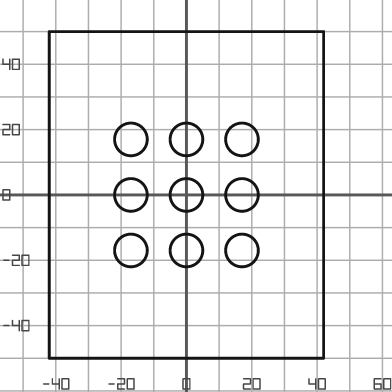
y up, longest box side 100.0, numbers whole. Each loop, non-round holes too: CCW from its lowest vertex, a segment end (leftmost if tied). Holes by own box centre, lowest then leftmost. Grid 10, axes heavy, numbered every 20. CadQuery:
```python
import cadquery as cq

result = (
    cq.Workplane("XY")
    .moveTo(-42.0, -50.0)
    .lineTo(42.0, -50.0)
    .lineTo(42.0, 50.0)
    .lineTo(-42.0, 50.0)
    .close()
    .moveTo(-17.0, -17.0)
    .circle(5.0)
    .moveTo(0.0, -17.0)
    .circle(5.0)
    .moveTo(17.0, -17.0)
    .circle(5.0)
    .moveTo(-17.0, 0.0)
    .circle(5.0)
    .moveTo(0.0, 0.0)
    .circle(5.0)
    .moveTo(17.0, 0.0)
    .circle(5.0)
    .moveTo(-17.0, 17.0)
    .circle(5.0)
    .moveTo(0.0, 17.0)
    .circle(5.0)
    .moveTo(17.0, 17.0)
    .circle(5.0)
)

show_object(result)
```